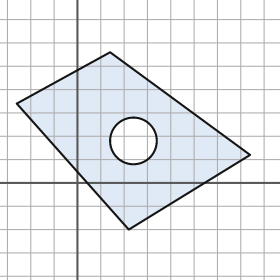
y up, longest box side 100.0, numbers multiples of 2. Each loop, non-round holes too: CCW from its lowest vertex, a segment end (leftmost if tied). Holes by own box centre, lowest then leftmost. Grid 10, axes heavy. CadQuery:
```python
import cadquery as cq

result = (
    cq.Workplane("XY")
    .moveTo(22.0, -20.0)
    .lineTo(74.0, 12.0)
    .lineTo(14.0, 56.0)
    .lineTo(-26.0, 34.0)
    .close()
    .moveTo(24.0, 18.0)
    .circle(10.0)
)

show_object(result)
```